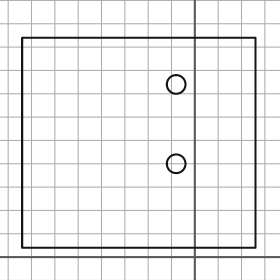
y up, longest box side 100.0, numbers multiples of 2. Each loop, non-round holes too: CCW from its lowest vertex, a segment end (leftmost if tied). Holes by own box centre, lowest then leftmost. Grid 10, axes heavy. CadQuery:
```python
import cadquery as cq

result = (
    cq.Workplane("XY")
    .moveTo(-74.0, 4.0)
    .lineTo(26.0, 4.0)
    .lineTo(26.0, 94.0)
    .lineTo(-74.0, 94.0)
    .close()
    .moveTo(-8.0, 40.0)
    .circle(4.0)
    .moveTo(-8.0, 74.0)
    .circle(4.0)
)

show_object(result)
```